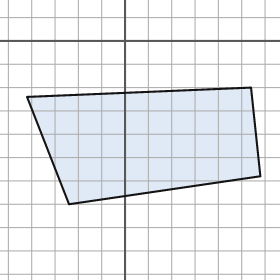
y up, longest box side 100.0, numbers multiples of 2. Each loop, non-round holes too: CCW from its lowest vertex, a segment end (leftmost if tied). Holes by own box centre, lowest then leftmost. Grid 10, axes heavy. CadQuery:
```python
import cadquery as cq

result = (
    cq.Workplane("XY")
    .moveTo(-24.0, -70.0)
    .lineTo(58.0, -58.0)
    .lineTo(54.0, -20.0)
    .lineTo(-42.0, -24.0)
    .close()
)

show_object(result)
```